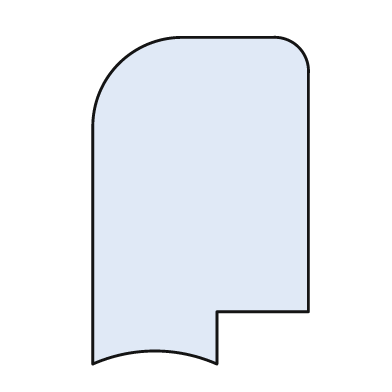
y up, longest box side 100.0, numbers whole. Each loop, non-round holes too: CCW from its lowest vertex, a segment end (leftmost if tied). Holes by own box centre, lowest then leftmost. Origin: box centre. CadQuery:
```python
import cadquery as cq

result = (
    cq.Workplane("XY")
    .moveTo(-33.0, -50.0)
    .threePointArc((-14.0, -46.0), (5.0, -50.0))
    .lineTo(5.0, -34.0)
    .lineTo(33.0, -34.0)
    .lineTo(33.0, 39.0)
    .threePointArc((30.0, 47.0), (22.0, 50.0))
    .lineTo(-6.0, 50.0)
    .threePointArc((-25.0, 42.0), (-33.0, 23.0))
    .close()
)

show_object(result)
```